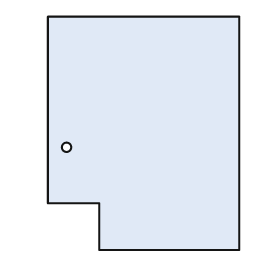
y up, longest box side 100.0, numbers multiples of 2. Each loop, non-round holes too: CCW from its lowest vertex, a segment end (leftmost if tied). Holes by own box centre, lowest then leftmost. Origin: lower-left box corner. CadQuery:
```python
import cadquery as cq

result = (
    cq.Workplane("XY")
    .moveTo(22.0, 0.0)
    .lineTo(82.0, 0.0)
    .lineTo(82.0, 100.0)
    .lineTo(0.0, 100.0)
    .lineTo(0.0, 20.0)
    .lineTo(22.0, 20.0)
    .close()
    .moveTo(8.0, 44.0)
    .circle(2.0)
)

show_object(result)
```